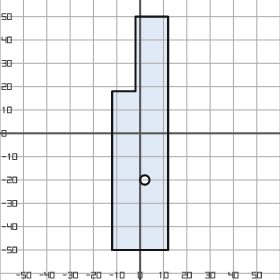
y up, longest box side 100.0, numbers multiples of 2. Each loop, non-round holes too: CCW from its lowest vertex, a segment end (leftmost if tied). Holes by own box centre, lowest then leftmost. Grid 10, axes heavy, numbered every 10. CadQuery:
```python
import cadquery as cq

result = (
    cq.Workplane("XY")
    .moveTo(-12.0, -50.0)
    .lineTo(12.0, -50.0)
    .lineTo(12.0, 50.0)
    .lineTo(-2.0, 50.0)
    .lineTo(-2.0, 18.0)
    .lineTo(-12.0, 18.0)
    .close()
    .moveTo(2.0, -20.0)
    .circle(2.0)
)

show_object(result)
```